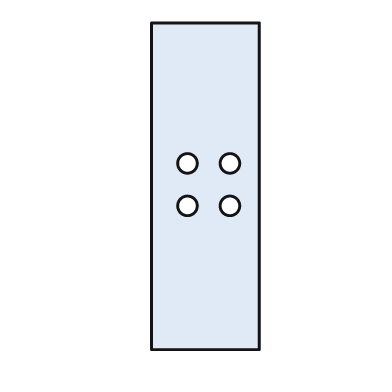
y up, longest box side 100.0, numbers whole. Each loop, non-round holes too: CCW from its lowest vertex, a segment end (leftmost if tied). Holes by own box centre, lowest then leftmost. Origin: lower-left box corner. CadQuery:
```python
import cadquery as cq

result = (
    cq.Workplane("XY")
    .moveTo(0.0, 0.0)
    .lineTo(33.0, 0.0)
    .lineTo(33.0, 100.0)
    .lineTo(0.0, 100.0)
    .close()
    .moveTo(11.0, 44.0)
    .circle(3.0)
    .moveTo(24.0, 44.0)
    .circle(3.0)
    .moveTo(11.0, 57.0)
    .circle(3.0)
    .moveTo(24.0, 57.0)
    .circle(3.0)
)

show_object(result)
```